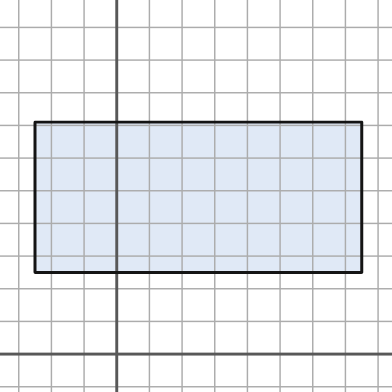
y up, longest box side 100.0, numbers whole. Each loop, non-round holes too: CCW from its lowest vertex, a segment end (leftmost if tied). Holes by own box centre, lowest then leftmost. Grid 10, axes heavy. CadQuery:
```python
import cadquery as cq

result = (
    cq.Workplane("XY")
    .moveTo(-25.0, 25.0)
    .lineTo(75.0, 25.0)
    .lineTo(75.0, 71.0)
    .lineTo(-25.0, 71.0)
    .close()
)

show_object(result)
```